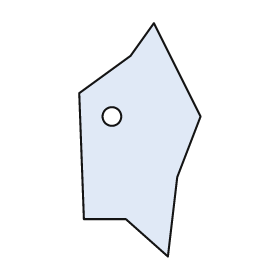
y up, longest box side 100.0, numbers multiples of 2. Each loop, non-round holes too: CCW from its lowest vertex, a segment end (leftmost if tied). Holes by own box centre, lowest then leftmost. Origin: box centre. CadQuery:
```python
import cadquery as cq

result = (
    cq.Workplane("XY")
    .moveTo(12.0, -50.0)
    .lineTo(16.0, -16.0)
    .lineTo(26.0, 10.0)
    .lineTo(6.0, 50.0)
    .lineTo(-4.0, 36.0)
    .lineTo(-26.0, 20.0)
    .lineTo(-24.0, -34.0)
    .lineTo(-6.0, -34.0)
    .close()
    .moveTo(-12.0, 10.0)
    .circle(4.0)
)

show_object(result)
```